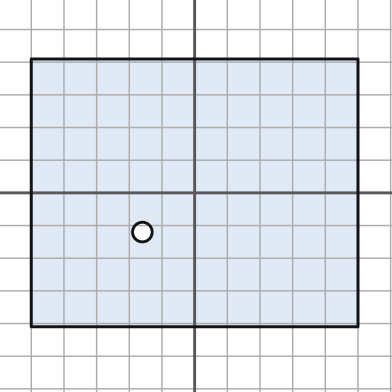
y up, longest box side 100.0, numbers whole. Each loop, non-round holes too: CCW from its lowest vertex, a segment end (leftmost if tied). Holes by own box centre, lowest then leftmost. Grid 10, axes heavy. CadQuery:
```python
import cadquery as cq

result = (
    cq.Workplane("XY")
    .moveTo(-50.0, -41.0)
    .lineTo(50.0, -41.0)
    .lineTo(50.0, 41.0)
    .lineTo(-50.0, 41.0)
    .close()
    .moveTo(-16.0, -12.0)
    .circle(3.0)
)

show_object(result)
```